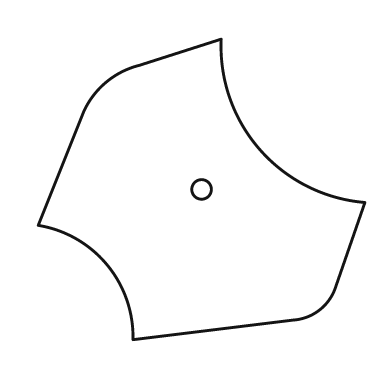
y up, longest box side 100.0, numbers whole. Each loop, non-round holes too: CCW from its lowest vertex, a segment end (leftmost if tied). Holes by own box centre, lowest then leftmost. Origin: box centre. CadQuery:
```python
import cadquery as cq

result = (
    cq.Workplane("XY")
    .moveTo(-21.0, -46.0)
    .lineTo(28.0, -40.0)
    .threePointArc((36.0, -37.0), (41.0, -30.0))
    .lineTo(50.0, -4.0)
    .threePointArc((18.0, 12.0), (6.0, 46.0))
    .lineTo(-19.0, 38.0)
    .threePointArc((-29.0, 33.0), (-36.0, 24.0))
    .lineTo(-50.0, -11.0)
    .threePointArc((-29.0, -23.0), (-21.0, -46.0))
    .close()
    .moveTo(0.0, 0.0)
    .circle(3.0)
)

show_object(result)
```